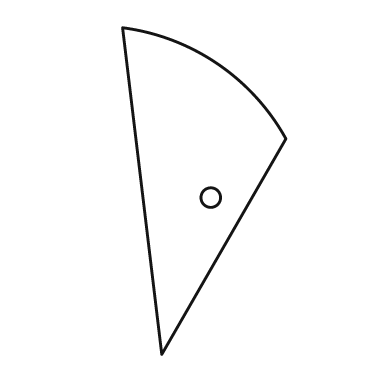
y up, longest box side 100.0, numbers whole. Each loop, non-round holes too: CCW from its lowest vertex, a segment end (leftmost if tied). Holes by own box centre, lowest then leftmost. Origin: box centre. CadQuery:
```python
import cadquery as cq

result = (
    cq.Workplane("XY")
    .moveTo(-13.0, -50.0)
    .lineTo(25.0, 16.0)
    .threePointArc((4.0, 39.0), (-25.0, 50.0))
    .close()
    .moveTo(2.0, -2.0)
    .circle(3.0)
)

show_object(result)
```